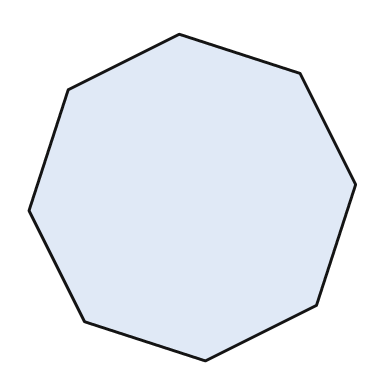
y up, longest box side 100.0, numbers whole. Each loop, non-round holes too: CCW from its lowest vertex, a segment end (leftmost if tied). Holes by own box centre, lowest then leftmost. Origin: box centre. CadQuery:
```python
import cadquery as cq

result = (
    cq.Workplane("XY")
    .moveTo(4.0, -50.0)
    .lineTo(38.0, -33.0)
    .lineTo(50.0, 4.0)
    .lineTo(33.0, 38.0)
    .lineTo(-4.0, 50.0)
    .lineTo(-38.0, 33.0)
    .lineTo(-50.0, -4.0)
    .lineTo(-33.0, -38.0)
    .close()
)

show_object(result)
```